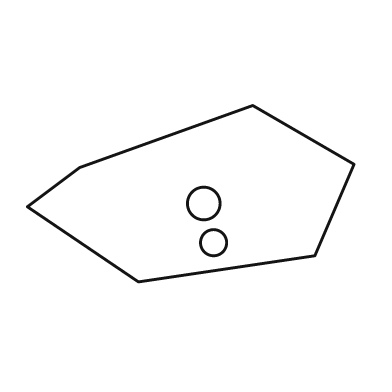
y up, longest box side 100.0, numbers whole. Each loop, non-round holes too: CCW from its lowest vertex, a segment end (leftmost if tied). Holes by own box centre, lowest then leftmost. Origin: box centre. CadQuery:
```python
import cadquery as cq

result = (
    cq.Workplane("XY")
    .moveTo(-16.0, -27.0)
    .lineTo(38.0, -19.0)
    .lineTo(50.0, 9.0)
    .lineTo(19.0, 27.0)
    .lineTo(-34.0, 8.0)
    .lineTo(-50.0, -4.0)
    .close()
    .moveTo(7.0, -15.0)
    .circle(4.0)
    .moveTo(4.0, -3.0)
    .circle(5.0)
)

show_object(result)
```